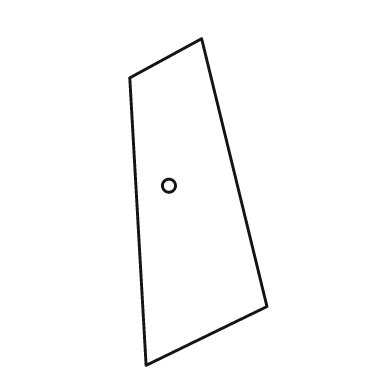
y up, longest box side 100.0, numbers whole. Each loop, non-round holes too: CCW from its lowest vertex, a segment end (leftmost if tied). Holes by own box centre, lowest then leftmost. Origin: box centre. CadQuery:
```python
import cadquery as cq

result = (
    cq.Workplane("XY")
    .moveTo(-16.0, -50.0)
    .lineTo(21.0, -32.0)
    .lineTo(1.0, 50.0)
    .lineTo(-21.0, 38.0)
    .close()
    .moveTo(-9.0, 5.0)
    .circle(2.0)
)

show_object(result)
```